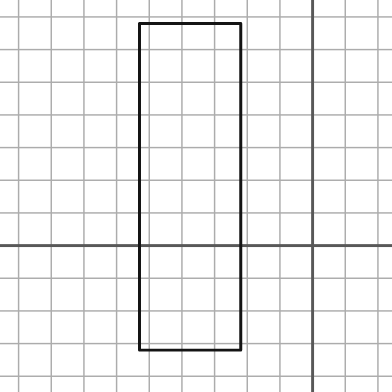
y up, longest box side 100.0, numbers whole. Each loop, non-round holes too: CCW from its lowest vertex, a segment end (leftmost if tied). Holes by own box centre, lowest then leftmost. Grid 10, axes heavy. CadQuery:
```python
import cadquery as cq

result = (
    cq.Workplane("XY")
    .moveTo(-53.0, -32.0)
    .lineTo(-22.0, -32.0)
    .lineTo(-22.0, 68.0)
    .lineTo(-53.0, 68.0)
    .close()
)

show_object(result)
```